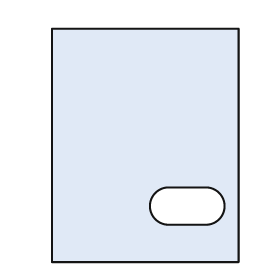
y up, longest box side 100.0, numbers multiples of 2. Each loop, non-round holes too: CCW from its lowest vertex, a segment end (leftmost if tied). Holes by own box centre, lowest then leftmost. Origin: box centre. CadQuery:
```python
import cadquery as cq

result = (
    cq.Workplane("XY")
    .moveTo(-40.0, -50.0)
    .lineTo(40.0, -50.0)
    .lineTo(40.0, 50.0)
    .lineTo(-40.0, 50.0)
    .close()
    .moveTo(10.0, -34.0)
    .lineTo(26.0, -34.0)
    .threePointArc((34.0, -26.0), (26.0, -18.0))
    .lineTo(10.0, -18.0)
    .threePointArc((2.0, -26.0), (10.0, -34.0))
    .close()
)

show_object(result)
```